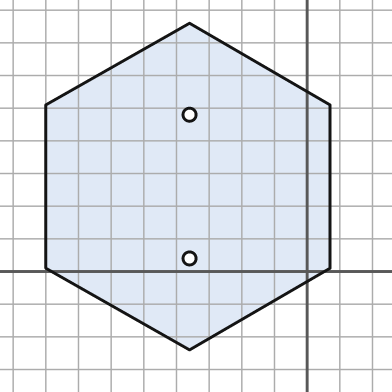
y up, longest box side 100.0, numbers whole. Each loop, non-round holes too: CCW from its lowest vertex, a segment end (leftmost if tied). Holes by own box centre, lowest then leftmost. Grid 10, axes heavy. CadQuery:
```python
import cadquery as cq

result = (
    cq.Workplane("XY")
    .moveTo(-36.0, -24.0)
    .lineTo(7.0, 1.0)
    .lineTo(7.0, 51.0)
    .lineTo(-36.0, 76.0)
    .lineTo(-80.0, 51.0)
    .lineTo(-80.0, 1.0)
    .close()
    .moveTo(-36.0, 4.0)
    .circle(2.0)
    .moveTo(-36.0, 48.0)
    .circle(2.0)
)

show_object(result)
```